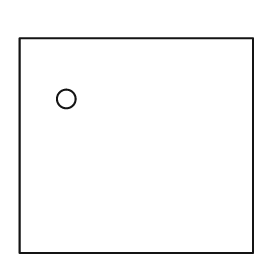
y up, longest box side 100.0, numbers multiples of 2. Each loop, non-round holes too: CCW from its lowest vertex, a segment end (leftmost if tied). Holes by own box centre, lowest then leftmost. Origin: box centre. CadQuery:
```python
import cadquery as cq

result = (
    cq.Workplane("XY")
    .moveTo(-50.0, -46.0)
    .lineTo(50.0, -46.0)
    .lineTo(50.0, 46.0)
    .lineTo(-50.0, 46.0)
    .close()
    .moveTo(-30.0, 20.0)
    .circle(4.0)
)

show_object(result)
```